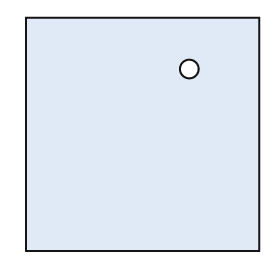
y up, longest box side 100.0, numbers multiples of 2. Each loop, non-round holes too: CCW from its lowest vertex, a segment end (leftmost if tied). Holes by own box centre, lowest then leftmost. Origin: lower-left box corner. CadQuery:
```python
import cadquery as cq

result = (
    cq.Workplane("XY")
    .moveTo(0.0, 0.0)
    .lineTo(100.0, 0.0)
    .lineTo(100.0, 100.0)
    .lineTo(0.0, 100.0)
    .close()
    .moveTo(70.0, 78.0)
    .circle(4.0)
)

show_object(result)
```